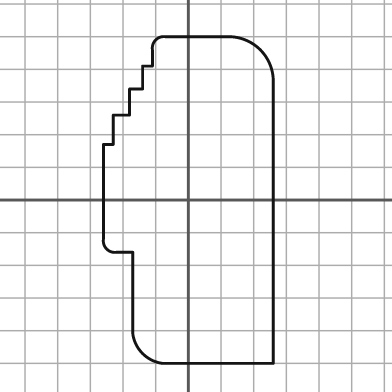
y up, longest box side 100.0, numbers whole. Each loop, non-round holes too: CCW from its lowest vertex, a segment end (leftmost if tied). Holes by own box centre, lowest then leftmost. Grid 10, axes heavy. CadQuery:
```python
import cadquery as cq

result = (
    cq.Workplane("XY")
    .moveTo(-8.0, -50.0)
    .lineTo(26.0, -50.0)
    .lineTo(26.0, 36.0)
    .threePointArc((22.0, 46.0), (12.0, 50.0))
    .lineTo(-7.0, 50.0)
    .threePointArc((-10.0, 49.0), (-11.0, 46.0))
    .lineTo(-11.0, 41.0)
    .lineTo(-14.0, 41.0)
    .lineTo(-14.0, 34.0)
    .lineTo(-18.0, 34.0)
    .lineTo(-18.0, 26.0)
    .lineTo(-23.0, 26.0)
    .lineTo(-23.0, 17.0)
    .lineTo(-26.0, 17.0)
    .lineTo(-26.0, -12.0)
    .threePointArc((-25.0, -15.0), (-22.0, -16.0))
    .lineTo(-17.0, -16.0)
    .lineTo(-17.0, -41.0)
    .threePointArc((-14.0, -47.0), (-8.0, -50.0))
    .close()
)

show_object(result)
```